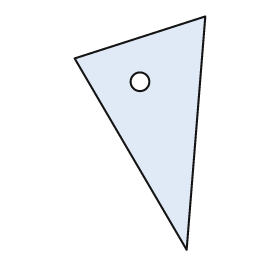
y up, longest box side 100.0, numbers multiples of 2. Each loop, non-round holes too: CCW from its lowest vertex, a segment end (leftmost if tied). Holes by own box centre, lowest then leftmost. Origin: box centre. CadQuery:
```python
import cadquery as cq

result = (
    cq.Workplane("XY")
    .moveTo(20.0, -50.0)
    .lineTo(28.0, 50.0)
    .lineTo(-28.0, 32.0)
    .close()
    .moveTo(0.0, 22.0)
    .circle(4.0)
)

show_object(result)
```